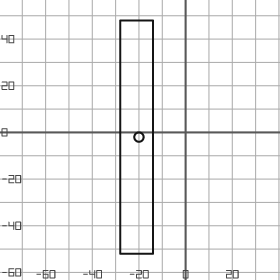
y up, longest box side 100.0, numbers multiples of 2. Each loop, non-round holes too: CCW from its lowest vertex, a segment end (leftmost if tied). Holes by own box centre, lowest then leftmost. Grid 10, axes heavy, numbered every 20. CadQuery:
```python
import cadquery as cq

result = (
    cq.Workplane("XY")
    .moveTo(-28.0, -52.0)
    .lineTo(-14.0, -52.0)
    .lineTo(-14.0, 48.0)
    .lineTo(-28.0, 48.0)
    .close()
    .moveTo(-20.0, -2.0)
    .circle(2.0)
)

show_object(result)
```